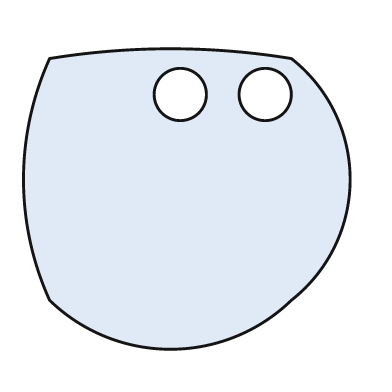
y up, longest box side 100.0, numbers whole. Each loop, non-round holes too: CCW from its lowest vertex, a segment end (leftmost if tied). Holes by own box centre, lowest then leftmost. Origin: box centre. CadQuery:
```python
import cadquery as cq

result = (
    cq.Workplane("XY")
    .moveTo(-42.0, -31.0)
    .threePointArc((-5.0, -46.0), (32.0, -31.0))
    .threePointArc((50.0, 6.0), (32.0, 43.0))
    .threePointArc((-5.0, 46.0), (-42.0, 43.0))
    .threePointArc((-50.0, 6.0), (-42.0, -31.0))
    .close()
    .moveTo(-2.0, 32.0)
    .circle(8.0)
    .moveTo(24.0, 32.0)
    .circle(8.0)
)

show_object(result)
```